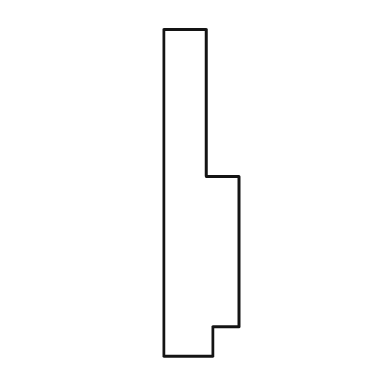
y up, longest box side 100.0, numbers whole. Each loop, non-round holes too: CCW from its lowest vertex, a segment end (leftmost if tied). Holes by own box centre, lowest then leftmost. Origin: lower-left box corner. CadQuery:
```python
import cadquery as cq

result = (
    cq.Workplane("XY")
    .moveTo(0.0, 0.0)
    .lineTo(15.0, 0.0)
    .lineTo(15.0, 9.0)
    .lineTo(23.0, 9.0)
    .lineTo(23.0, 55.0)
    .lineTo(13.0, 55.0)
    .lineTo(13.0, 100.0)
    .lineTo(0.0, 100.0)
    .close()
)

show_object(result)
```